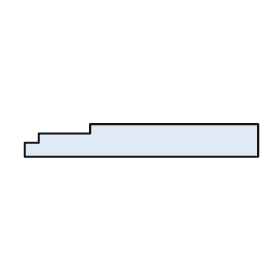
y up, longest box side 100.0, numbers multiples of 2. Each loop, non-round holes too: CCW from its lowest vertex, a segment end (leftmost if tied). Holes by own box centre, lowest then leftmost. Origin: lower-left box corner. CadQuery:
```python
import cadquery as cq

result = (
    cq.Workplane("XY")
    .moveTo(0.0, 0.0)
    .lineTo(100.0, 0.0)
    .lineTo(100.0, 14.0)
    .lineTo(28.0, 14.0)
    .lineTo(28.0, 10.0)
    .lineTo(6.0, 10.0)
    .lineTo(6.0, 6.0)
    .lineTo(0.0, 6.0)
    .close()
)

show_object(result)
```